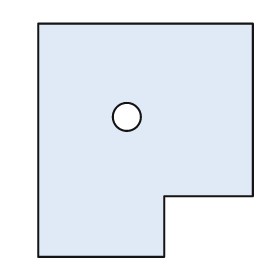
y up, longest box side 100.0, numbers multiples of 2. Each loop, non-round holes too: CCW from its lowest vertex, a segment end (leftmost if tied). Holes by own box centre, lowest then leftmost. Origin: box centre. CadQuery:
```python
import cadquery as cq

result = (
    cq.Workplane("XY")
    .moveTo(-46.0, -50.0)
    .lineTo(8.0, -50.0)
    .lineTo(8.0, -24.0)
    .lineTo(46.0, -24.0)
    .lineTo(46.0, 50.0)
    .lineTo(-46.0, 50.0)
    .close()
    .moveTo(-8.0, 10.0)
    .circle(6.0)
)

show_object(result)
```